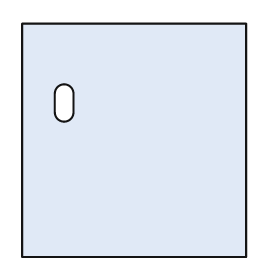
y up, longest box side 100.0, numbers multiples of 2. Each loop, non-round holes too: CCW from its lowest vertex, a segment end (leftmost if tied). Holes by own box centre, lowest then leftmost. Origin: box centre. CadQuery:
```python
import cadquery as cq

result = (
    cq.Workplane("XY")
    .moveTo(-48.0, -50.0)
    .lineTo(48.0, -50.0)
    .lineTo(48.0, 50.0)
    .lineTo(-48.0, 50.0)
    .close()
    .moveTo(-34.0, 12.0)
    .threePointArc((-30.0, 8.0), (-26.0, 12.0))
    .lineTo(-26.0, 20.0)
    .threePointArc((-30.0, 24.0), (-34.0, 20.0))
    .close()
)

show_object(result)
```